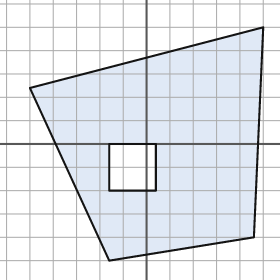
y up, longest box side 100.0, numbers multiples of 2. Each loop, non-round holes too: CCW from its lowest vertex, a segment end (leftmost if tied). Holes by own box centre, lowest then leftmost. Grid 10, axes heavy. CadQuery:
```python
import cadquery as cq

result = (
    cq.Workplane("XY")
    .moveTo(-16.0, -50.0)
    .lineTo(46.0, -40.0)
    .lineTo(50.0, 50.0)
    .lineTo(-50.0, 24.0)
    .close()
    .moveTo(-16.0, -20.0)
    .lineTo(4.0, -20.0)
    .lineTo(4.0, 0.0)
    .lineTo(-16.0, 0.0)
    .close()
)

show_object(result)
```